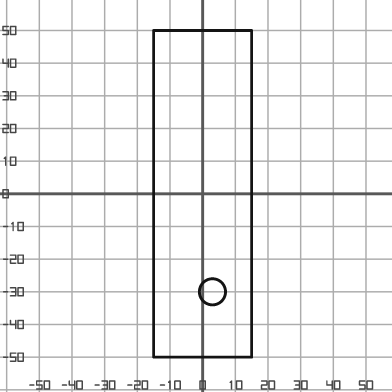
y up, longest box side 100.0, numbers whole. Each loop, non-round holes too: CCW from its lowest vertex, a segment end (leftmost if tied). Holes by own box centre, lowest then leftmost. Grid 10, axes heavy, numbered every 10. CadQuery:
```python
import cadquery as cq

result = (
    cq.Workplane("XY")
    .moveTo(-15.0, -50.0)
    .lineTo(15.0, -50.0)
    .lineTo(15.0, 50.0)
    .lineTo(-15.0, 50.0)
    .close()
    .moveTo(3.0, -30.0)
    .circle(4.0)
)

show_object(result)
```